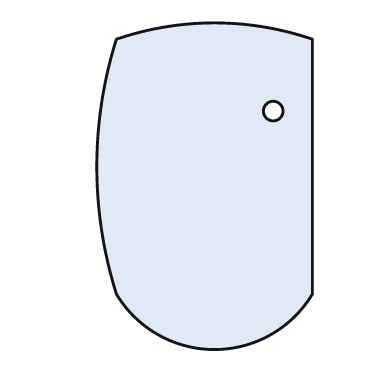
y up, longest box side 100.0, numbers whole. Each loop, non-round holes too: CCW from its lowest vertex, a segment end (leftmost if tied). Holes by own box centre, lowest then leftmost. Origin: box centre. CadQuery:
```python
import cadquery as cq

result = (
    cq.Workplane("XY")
    .moveTo(-27.0, -33.0)
    .threePointArc((3.0, -50.0), (33.0, -33.0))
    .lineTo(33.0, 45.0)
    .threePointArc((3.0, 50.0), (-27.0, 45.0))
    .threePointArc((-33.0, 6.0), (-27.0, -33.0))
    .close()
    .moveTo(21.0, 23.0)
    .circle(3.0)
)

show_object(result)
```